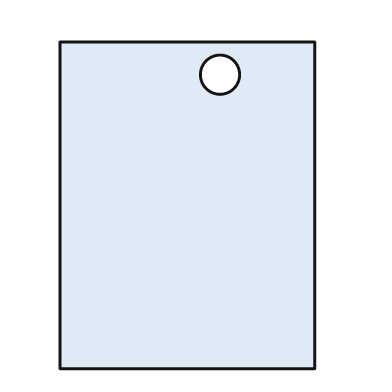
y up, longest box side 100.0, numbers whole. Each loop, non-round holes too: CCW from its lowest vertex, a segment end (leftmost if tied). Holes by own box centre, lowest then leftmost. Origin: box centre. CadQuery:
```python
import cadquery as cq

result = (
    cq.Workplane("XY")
    .moveTo(-39.0, -50.0)
    .lineTo(39.0, -50.0)
    .lineTo(39.0, 50.0)
    .lineTo(-39.0, 50.0)
    .close()
    .moveTo(10.0, 40.0)
    .circle(6.0)
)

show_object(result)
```